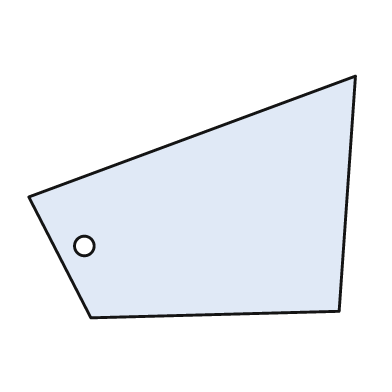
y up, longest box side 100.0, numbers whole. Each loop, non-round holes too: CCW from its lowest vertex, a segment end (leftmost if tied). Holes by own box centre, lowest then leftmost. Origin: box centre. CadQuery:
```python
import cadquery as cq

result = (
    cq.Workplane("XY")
    .moveTo(-31.0, -37.0)
    .lineTo(45.0, -35.0)
    .lineTo(50.0, 37.0)
    .lineTo(-50.0, 0.0)
    .close()
    .moveTo(-33.0, -15.0)
    .circle(3.0)
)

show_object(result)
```